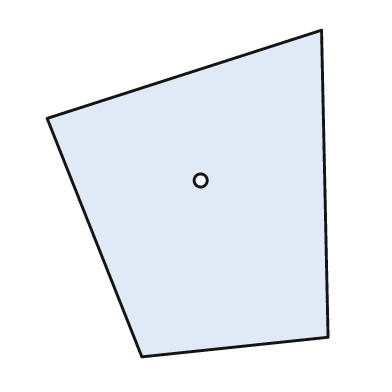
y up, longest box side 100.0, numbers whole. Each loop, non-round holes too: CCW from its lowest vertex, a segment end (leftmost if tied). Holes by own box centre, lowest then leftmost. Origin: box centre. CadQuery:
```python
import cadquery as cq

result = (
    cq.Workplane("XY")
    .moveTo(-14.0, -50.0)
    .lineTo(43.0, -44.0)
    .lineTo(41.0, 50.0)
    .lineTo(-43.0, 23.0)
    .close()
    .moveTo(4.0, 4.0)
    .circle(2.0)
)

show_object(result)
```